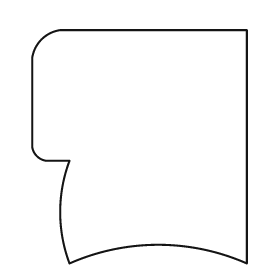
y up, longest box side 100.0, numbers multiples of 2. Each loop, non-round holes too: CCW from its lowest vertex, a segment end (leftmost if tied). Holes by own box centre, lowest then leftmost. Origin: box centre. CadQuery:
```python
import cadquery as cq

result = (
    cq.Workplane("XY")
    .moveTo(-30.0, -50.0)
    .threePointArc((8.0, -42.0), (46.0, -50.0))
    .lineTo(46.0, 50.0)
    .lineTo(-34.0, 50.0)
    .threePointArc((-42.0, 46.0), (-46.0, 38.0))
    .lineTo(-46.0, 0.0)
    .threePointArc((-44.0, -4.0), (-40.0, -6.0))
    .lineTo(-30.0, -6.0)
    .threePointArc((-34.0, -28.0), (-30.0, -50.0))
    .close()
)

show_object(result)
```